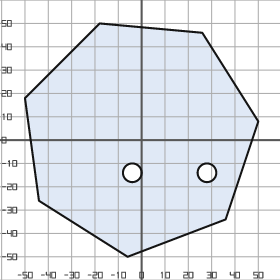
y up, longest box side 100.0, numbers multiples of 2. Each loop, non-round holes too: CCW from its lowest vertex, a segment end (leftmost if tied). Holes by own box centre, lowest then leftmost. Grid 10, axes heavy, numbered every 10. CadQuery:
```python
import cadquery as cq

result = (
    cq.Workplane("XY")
    .moveTo(-6.0, -50.0)
    .lineTo(36.0, -34.0)
    .lineTo(50.0, 8.0)
    .lineTo(26.0, 46.0)
    .lineTo(-18.0, 50.0)
    .lineTo(-50.0, 18.0)
    .lineTo(-44.0, -26.0)
    .close()
    .moveTo(-4.0, -14.0)
    .circle(4.0)
    .moveTo(28.0, -14.0)
    .circle(4.0)
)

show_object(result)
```